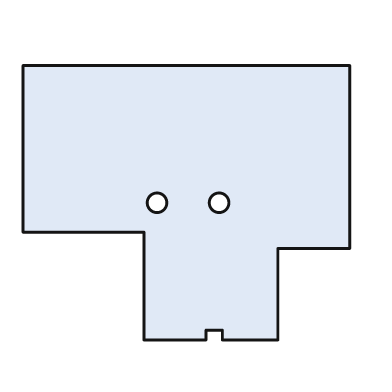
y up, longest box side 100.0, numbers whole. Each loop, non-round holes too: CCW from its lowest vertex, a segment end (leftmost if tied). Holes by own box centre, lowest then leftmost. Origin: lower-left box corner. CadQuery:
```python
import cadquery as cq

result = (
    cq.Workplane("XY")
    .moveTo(37.0, 0.0)
    .lineTo(56.0, 0.0)
    .lineTo(56.0, 3.0)
    .lineTo(61.0, 3.0)
    .lineTo(61.0, 0.0)
    .lineTo(78.0, 0.0)
    .lineTo(78.0, 28.0)
    .lineTo(100.0, 28.0)
    .lineTo(100.0, 84.0)
    .lineTo(0.0, 84.0)
    .lineTo(0.0, 33.0)
    .lineTo(37.0, 33.0)
    .close()
    .moveTo(41.0, 42.0)
    .circle(3.0)
    .moveTo(60.0, 42.0)
    .circle(3.0)
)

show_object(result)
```